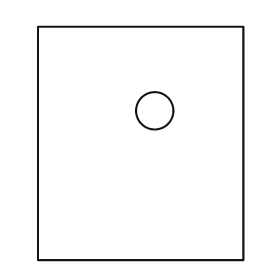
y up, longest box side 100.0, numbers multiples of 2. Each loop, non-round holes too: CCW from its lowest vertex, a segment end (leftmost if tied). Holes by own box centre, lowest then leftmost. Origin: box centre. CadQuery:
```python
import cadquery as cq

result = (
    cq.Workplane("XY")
    .moveTo(-44.0, -50.0)
    .lineTo(44.0, -50.0)
    .lineTo(44.0, 50.0)
    .lineTo(-44.0, 50.0)
    .close()
    .moveTo(6.0, 14.0)
    .circle(8.0)
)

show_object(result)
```